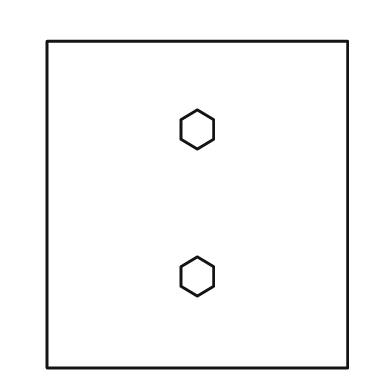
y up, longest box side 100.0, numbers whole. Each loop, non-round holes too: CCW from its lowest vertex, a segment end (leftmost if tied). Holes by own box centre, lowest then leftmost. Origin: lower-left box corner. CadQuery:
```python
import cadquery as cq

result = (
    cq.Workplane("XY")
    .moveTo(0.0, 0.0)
    .lineTo(92.0, 0.0)
    .lineTo(92.0, 100.0)
    .lineTo(0.0, 100.0)
    .close()
    .moveTo(46.0, 22.0)
    .lineTo(51.0, 25.0)
    .lineTo(51.0, 31.0)
    .lineTo(46.0, 34.0)
    .lineTo(41.0, 31.0)
    .lineTo(41.0, 25.0)
    .close()
    .moveTo(46.0, 67.0)
    .lineTo(51.0, 70.0)
    .lineTo(51.0, 76.0)
    .lineTo(46.0, 79.0)
    .lineTo(41.0, 76.0)
    .lineTo(41.0, 70.0)
    .close()
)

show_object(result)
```